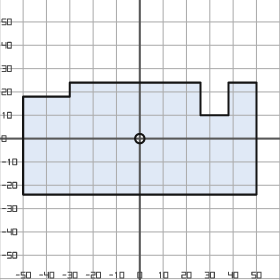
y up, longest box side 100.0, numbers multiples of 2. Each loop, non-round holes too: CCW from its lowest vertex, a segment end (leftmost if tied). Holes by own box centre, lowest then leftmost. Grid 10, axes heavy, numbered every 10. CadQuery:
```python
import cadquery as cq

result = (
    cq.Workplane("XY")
    .moveTo(-50.0, -24.0)
    .lineTo(50.0, -24.0)
    .lineTo(50.0, 24.0)
    .lineTo(38.0, 24.0)
    .lineTo(38.0, 10.0)
    .lineTo(26.0, 10.0)
    .lineTo(26.0, 24.0)
    .lineTo(-30.0, 24.0)
    .lineTo(-30.0, 18.0)
    .lineTo(-50.0, 18.0)
    .close()
    .moveTo(0.0, 0.0)
    .circle(2.0)
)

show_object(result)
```